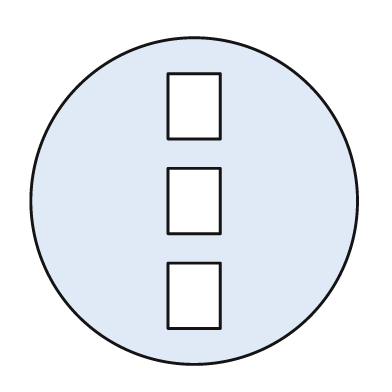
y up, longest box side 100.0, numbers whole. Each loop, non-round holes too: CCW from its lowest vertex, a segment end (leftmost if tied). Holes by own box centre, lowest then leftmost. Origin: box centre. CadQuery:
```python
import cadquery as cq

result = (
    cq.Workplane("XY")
    .moveTo(0.0, 0.0)
    .circle(50.0)
    .moveTo(-8.0, -39.0)
    .lineTo(8.0, -39.0)
    .lineTo(8.0, -19.0)
    .lineTo(-8.0, -19.0)
    .close()
    .moveTo(-8.0, -10.0)
    .lineTo(8.0, -10.0)
    .lineTo(8.0, 10.0)
    .lineTo(-8.0, 10.0)
    .close()
    .moveTo(-8.0, 19.0)
    .lineTo(8.0, 19.0)
    .lineTo(8.0, 39.0)
    .lineTo(-8.0, 39.0)
    .close()
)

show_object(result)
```